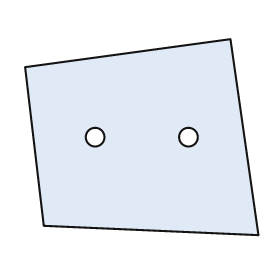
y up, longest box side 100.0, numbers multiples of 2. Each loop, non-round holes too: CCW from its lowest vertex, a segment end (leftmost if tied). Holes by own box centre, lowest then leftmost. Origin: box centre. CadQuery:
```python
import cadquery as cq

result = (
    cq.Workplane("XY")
    .moveTo(50.0, -42.0)
    .lineTo(38.0, 42.0)
    .lineTo(-50.0, 30.0)
    .lineTo(-42.0, -38.0)
    .close()
    .moveTo(-20.0, 0.0)
    .circle(4.0)
    .moveTo(20.0, 0.0)
    .circle(4.0)
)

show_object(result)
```